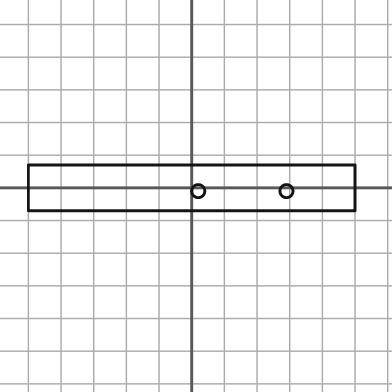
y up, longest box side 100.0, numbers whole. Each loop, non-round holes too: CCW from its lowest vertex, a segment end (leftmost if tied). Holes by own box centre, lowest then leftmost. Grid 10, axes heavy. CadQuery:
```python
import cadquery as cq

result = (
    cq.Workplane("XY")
    .moveTo(-50.0, -7.0)
    .lineTo(50.0, -7.0)
    .lineTo(50.0, 7.0)
    .lineTo(-50.0, 7.0)
    .close()
    .moveTo(2.0, -1.0)
    .circle(2.0)
    .moveTo(29.0, -1.0)
    .circle(2.0)
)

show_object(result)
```